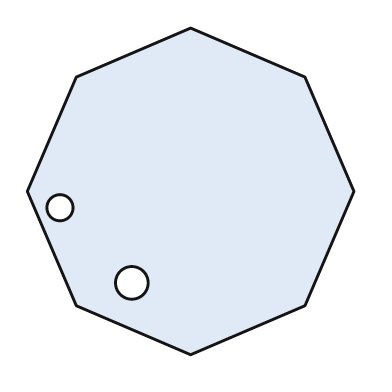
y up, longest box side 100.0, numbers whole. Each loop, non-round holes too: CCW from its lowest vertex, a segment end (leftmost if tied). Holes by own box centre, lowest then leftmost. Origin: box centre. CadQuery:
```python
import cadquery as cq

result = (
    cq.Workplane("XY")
    .moveTo(0.0, -50.0)
    .lineTo(35.0, -35.0)
    .lineTo(50.0, 0.0)
    .lineTo(35.0, 35.0)
    .lineTo(0.0, 50.0)
    .lineTo(-35.0, 35.0)
    .lineTo(-50.0, 0.0)
    .lineTo(-35.0, -35.0)
    .close()
    .moveTo(-18.0, -28.0)
    .circle(5.0)
    .moveTo(-40.0, -5.0)
    .circle(4.0)
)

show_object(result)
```